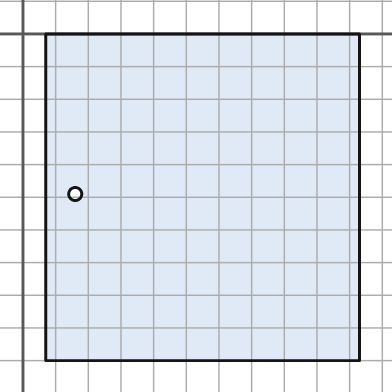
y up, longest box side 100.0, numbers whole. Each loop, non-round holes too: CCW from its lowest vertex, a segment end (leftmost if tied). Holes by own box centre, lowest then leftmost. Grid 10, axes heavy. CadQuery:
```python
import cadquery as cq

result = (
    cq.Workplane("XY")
    .moveTo(7.0, -100.0)
    .lineTo(103.0, -100.0)
    .lineTo(103.0, 0.0)
    .lineTo(7.0, 0.0)
    .close()
    .moveTo(16.0, -49.0)
    .circle(2.0)
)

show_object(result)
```